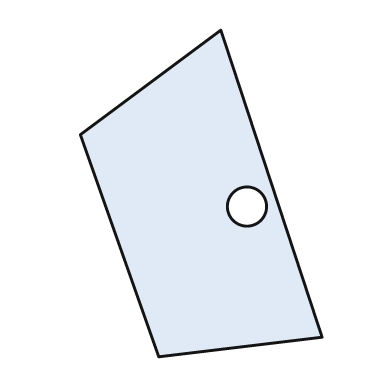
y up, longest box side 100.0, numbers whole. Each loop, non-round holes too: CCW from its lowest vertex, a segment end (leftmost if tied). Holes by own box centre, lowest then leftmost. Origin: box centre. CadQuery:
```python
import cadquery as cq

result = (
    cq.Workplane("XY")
    .moveTo(-13.0, -50.0)
    .lineTo(37.0, -44.0)
    .lineTo(6.0, 50.0)
    .lineTo(-37.0, 18.0)
    .close()
    .moveTo(14.0, -4.0)
    .circle(6.0)
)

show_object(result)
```